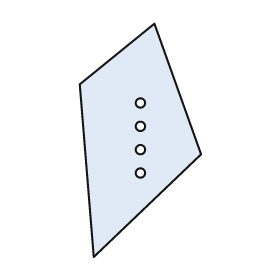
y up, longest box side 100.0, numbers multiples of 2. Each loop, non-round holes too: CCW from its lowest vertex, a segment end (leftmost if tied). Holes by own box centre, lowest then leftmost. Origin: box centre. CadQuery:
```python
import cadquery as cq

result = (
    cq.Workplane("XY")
    .moveTo(-20.0, -50.0)
    .lineTo(26.0, -6.0)
    .lineTo(6.0, 50.0)
    .lineTo(-26.0, 24.0)
    .close()
    .moveTo(0.0, -14.0)
    .circle(2.0)
    .moveTo(0.0, -4.0)
    .circle(2.0)
    .moveTo(0.0, 6.0)
    .circle(2.0)
    .moveTo(0.0, 16.0)
    .circle(2.0)
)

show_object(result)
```